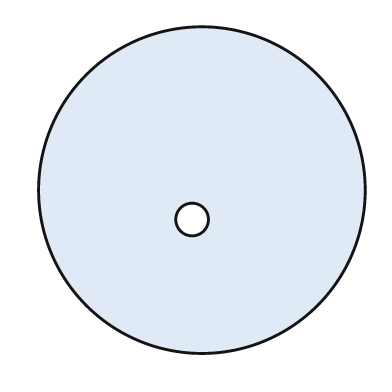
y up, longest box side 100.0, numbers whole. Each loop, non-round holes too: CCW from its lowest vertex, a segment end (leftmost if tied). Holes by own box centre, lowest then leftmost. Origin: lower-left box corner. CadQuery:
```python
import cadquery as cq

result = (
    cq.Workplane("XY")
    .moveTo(50.0, 50.0)
    .circle(50.0)
    .moveTo(47.0, 41.0)
    .circle(5.0)
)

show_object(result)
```